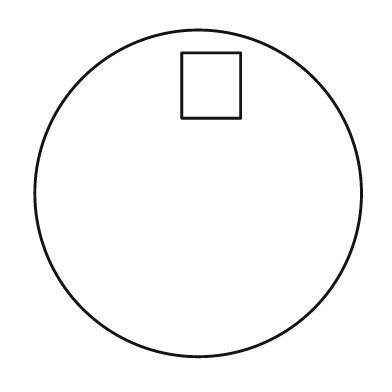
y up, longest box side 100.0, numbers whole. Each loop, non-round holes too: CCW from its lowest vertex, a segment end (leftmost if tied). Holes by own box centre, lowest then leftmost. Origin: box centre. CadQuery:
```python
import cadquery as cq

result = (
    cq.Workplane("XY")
    .moveTo(0.0, 0.0)
    .circle(50.0)
    .moveTo(-5.0, 23.0)
    .lineTo(13.0, 23.0)
    .lineTo(13.0, 43.0)
    .lineTo(-5.0, 43.0)
    .close()
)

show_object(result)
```